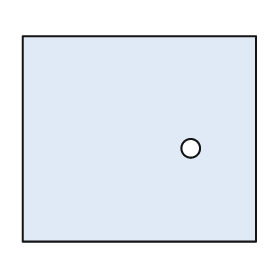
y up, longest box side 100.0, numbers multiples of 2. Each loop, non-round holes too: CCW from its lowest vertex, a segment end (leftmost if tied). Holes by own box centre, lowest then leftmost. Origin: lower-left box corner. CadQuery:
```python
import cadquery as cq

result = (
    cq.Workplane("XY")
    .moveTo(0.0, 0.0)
    .lineTo(100.0, 0.0)
    .lineTo(100.0, 88.0)
    .lineTo(0.0, 88.0)
    .close()
    .moveTo(72.0, 40.0)
    .circle(4.0)
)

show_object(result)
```